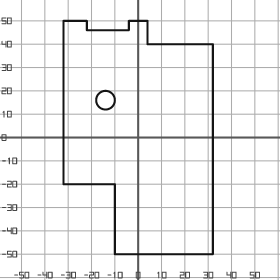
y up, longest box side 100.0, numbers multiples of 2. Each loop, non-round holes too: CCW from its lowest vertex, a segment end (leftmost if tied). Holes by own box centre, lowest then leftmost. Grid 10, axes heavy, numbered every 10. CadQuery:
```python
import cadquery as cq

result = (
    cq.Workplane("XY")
    .moveTo(-10.0, -50.0)
    .lineTo(32.0, -50.0)
    .lineTo(32.0, 40.0)
    .lineTo(4.0, 40.0)
    .lineTo(4.0, 50.0)
    .lineTo(-4.0, 50.0)
    .lineTo(-4.0, 46.0)
    .lineTo(-22.0, 46.0)
    .lineTo(-22.0, 50.0)
    .lineTo(-32.0, 50.0)
    .lineTo(-32.0, -20.0)
    .lineTo(-10.0, -20.0)
    .close()
    .moveTo(-14.0, 16.0)
    .circle(4.0)
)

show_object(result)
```